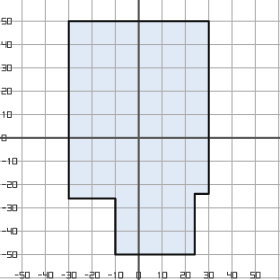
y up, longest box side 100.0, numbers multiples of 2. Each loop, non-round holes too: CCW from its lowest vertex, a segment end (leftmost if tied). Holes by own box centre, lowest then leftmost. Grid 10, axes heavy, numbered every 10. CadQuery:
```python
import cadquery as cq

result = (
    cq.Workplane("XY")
    .moveTo(-10.0, -50.0)
    .lineTo(24.0, -50.0)
    .lineTo(24.0, -24.0)
    .lineTo(30.0, -24.0)
    .lineTo(30.0, 50.0)
    .lineTo(-30.0, 50.0)
    .lineTo(-30.0, -26.0)
    .lineTo(-10.0, -26.0)
    .close()
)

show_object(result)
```